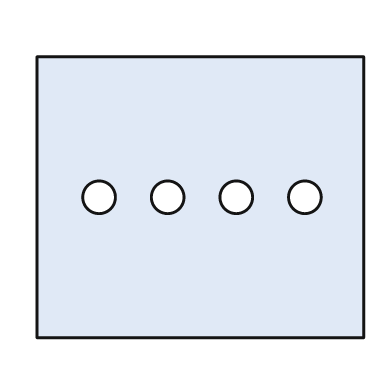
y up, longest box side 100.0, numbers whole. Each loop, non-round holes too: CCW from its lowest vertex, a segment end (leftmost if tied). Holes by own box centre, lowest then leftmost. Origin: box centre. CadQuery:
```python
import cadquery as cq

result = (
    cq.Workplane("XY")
    .moveTo(-50.0, -43.0)
    .lineTo(50.0, -43.0)
    .lineTo(50.0, 43.0)
    .lineTo(-50.0, 43.0)
    .close()
    .moveTo(-31.0, 0.0)
    .circle(5.0)
    .moveTo(-10.0, 0.0)
    .circle(5.0)
    .moveTo(11.0, 0.0)
    .circle(5.0)
    .moveTo(32.0, 0.0)
    .circle(5.0)
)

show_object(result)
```